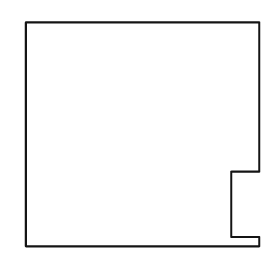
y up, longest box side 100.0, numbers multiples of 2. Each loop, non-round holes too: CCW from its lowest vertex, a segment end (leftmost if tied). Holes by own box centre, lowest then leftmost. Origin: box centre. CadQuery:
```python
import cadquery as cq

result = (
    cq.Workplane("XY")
    .moveTo(-50.0, -48.0)
    .lineTo(50.0, -48.0)
    .lineTo(50.0, -44.0)
    .lineTo(38.0, -44.0)
    .lineTo(38.0, -16.0)
    .lineTo(50.0, -16.0)
    .lineTo(50.0, 48.0)
    .lineTo(-50.0, 48.0)
    .close()
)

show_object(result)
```